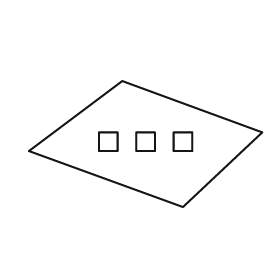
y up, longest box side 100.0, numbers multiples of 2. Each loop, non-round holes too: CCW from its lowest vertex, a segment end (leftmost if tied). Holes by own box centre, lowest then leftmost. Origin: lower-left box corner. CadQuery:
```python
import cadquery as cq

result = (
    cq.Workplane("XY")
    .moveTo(66.0, 0.0)
    .lineTo(100.0, 32.0)
    .lineTo(40.0, 54.0)
    .lineTo(0.0, 24.0)
    .close()
    .moveTo(30.0, 24.0)
    .lineTo(38.0, 24.0)
    .lineTo(38.0, 32.0)
    .lineTo(30.0, 32.0)
    .close()
    .moveTo(46.0, 24.0)
    .lineTo(54.0, 24.0)
    .lineTo(54.0, 32.0)
    .lineTo(46.0, 32.0)
    .close()
    .moveTo(62.0, 24.0)
    .lineTo(70.0, 24.0)
    .lineTo(70.0, 32.0)
    .lineTo(62.0, 32.0)
    .close()
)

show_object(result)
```